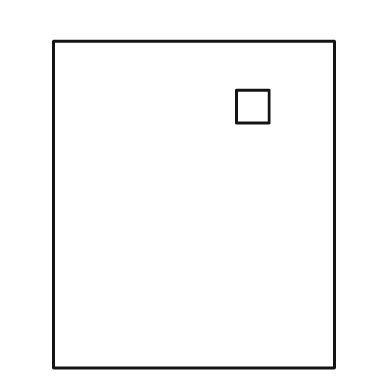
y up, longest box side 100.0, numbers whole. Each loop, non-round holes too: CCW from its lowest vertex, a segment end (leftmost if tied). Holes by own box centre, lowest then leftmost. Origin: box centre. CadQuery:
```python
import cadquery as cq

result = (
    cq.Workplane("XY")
    .moveTo(-43.0, -50.0)
    .lineTo(43.0, -50.0)
    .lineTo(43.0, 50.0)
    .lineTo(-43.0, 50.0)
    .close()
    .moveTo(13.0, 25.0)
    .lineTo(23.0, 25.0)
    .lineTo(23.0, 35.0)
    .lineTo(13.0, 35.0)
    .close()
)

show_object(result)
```